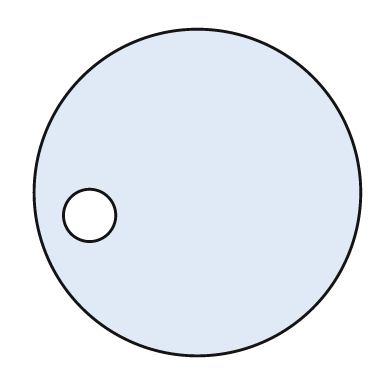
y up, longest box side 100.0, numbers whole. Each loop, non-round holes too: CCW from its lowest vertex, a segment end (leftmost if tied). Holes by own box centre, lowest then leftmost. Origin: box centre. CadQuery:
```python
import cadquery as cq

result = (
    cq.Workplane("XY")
    .moveTo(0.0, 0.0)
    .circle(50.0)
    .moveTo(-33.0, -7.0)
    .circle(8.0)
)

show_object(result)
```